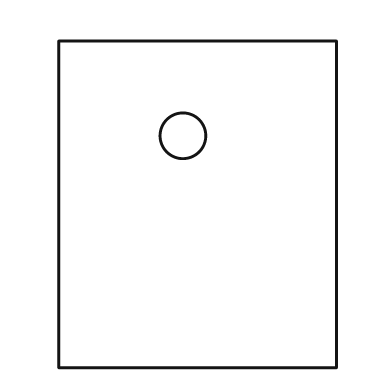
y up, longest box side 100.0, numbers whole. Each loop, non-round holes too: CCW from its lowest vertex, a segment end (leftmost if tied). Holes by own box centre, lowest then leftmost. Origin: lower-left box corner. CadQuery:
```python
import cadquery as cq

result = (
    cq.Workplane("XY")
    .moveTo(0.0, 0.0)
    .lineTo(85.0, 0.0)
    .lineTo(85.0, 100.0)
    .lineTo(0.0, 100.0)
    .close()
    .moveTo(38.0, 71.0)
    .circle(7.0)
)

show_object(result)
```